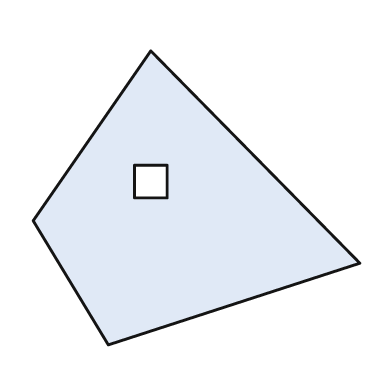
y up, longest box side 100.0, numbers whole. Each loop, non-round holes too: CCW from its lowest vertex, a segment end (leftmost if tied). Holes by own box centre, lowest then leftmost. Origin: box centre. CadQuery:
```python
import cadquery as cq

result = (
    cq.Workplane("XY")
    .moveTo(-27.0, -45.0)
    .lineTo(50.0, -20.0)
    .lineTo(-14.0, 45.0)
    .lineTo(-50.0, -7.0)
    .close()
    .moveTo(-19.0, 0.0)
    .lineTo(-9.0, 0.0)
    .lineTo(-9.0, 10.0)
    .lineTo(-19.0, 10.0)
    .close()
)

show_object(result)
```